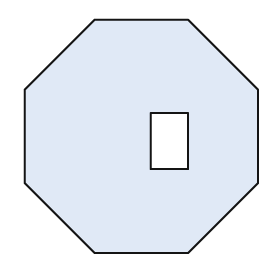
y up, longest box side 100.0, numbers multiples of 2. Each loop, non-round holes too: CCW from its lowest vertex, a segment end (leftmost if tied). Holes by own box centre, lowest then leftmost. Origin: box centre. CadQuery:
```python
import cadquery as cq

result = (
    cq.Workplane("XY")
    .moveTo(-20.0, -50.0)
    .lineTo(20.0, -50.0)
    .lineTo(50.0, -20.0)
    .lineTo(50.0, 20.0)
    .lineTo(20.0, 50.0)
    .lineTo(-20.0, 50.0)
    .lineTo(-50.0, 20.0)
    .lineTo(-50.0, -20.0)
    .close()
    .moveTo(4.0, -14.0)
    .lineTo(20.0, -14.0)
    .lineTo(20.0, 10.0)
    .lineTo(4.0, 10.0)
    .close()
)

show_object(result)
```